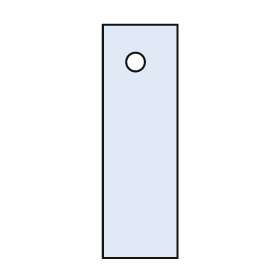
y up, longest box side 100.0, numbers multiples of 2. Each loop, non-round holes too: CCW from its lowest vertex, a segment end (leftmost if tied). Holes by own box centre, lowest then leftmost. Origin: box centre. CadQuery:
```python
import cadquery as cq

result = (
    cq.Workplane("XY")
    .moveTo(-16.0, -50.0)
    .lineTo(16.0, -50.0)
    .lineTo(16.0, 50.0)
    .lineTo(-16.0, 50.0)
    .close()
    .moveTo(-2.0, 34.0)
    .circle(4.0)
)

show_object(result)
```